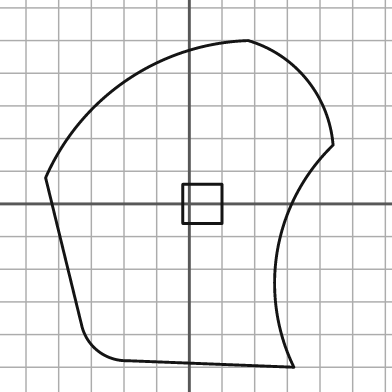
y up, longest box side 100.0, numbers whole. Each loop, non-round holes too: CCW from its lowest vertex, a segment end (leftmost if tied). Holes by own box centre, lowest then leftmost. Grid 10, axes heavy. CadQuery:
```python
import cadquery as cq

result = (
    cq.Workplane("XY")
    .moveTo(32.0, -50.0)
    .threePointArc((27.0, -14.0), (44.0, 18.0))
    .threePointArc((36.0, 38.0), (18.0, 50.0))
    .threePointArc((-19.0, 38.0), (-44.0, 8.0))
    .lineTo(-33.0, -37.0)
    .threePointArc((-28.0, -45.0), (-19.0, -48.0))
    .close()
    .moveTo(-2.0, -6.0)
    .lineTo(10.0, -6.0)
    .lineTo(10.0, 6.0)
    .lineTo(-2.0, 6.0)
    .close()
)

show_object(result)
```